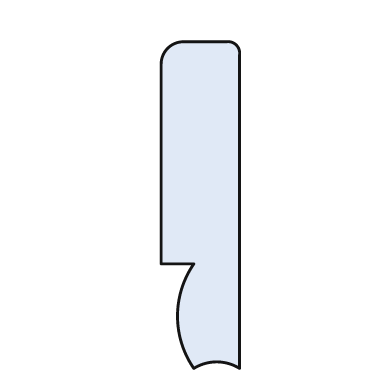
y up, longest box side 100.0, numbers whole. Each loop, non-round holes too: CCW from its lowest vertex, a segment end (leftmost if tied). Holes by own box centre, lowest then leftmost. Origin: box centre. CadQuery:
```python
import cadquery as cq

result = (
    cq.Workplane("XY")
    .moveTo(-2.0, -50.0)
    .threePointArc((5.0, -48.0), (12.0, -50.0))
    .lineTo(12.0, 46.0)
    .threePointArc((11.0, 49.0), (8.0, 50.0))
    .lineTo(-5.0, 50.0)
    .threePointArc((-10.0, 48.0), (-12.0, 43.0))
    .lineTo(-12.0, -18.0)
    .lineTo(-2.0, -18.0)
    .threePointArc((-7.0, -34.0), (-2.0, -50.0))
    .close()
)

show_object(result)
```